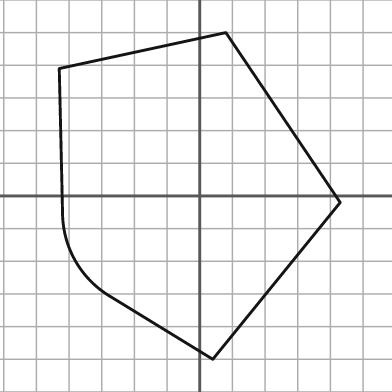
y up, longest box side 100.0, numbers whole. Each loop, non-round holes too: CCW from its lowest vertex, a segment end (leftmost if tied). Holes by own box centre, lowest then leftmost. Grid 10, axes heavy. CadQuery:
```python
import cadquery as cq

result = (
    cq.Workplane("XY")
    .moveTo(4.0, -50.0)
    .lineTo(43.0, -2.0)
    .lineTo(8.0, 50.0)
    .lineTo(-43.0, 39.0)
    .lineTo(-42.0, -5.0)
    .threePointArc((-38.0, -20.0), (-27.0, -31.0))
    .close()
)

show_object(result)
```